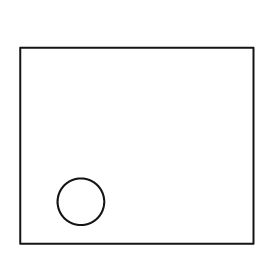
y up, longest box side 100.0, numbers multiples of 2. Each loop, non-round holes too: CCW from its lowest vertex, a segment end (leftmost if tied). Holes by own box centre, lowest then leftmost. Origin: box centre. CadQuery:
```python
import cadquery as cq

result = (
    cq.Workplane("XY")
    .moveTo(-50.0, -42.0)
    .lineTo(50.0, -42.0)
    .lineTo(50.0, 42.0)
    .lineTo(-50.0, 42.0)
    .close()
    .moveTo(-24.0, -24.0)
    .circle(10.0)
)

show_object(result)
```